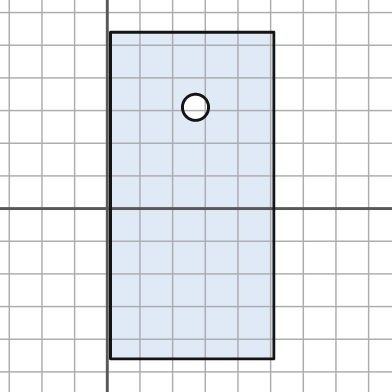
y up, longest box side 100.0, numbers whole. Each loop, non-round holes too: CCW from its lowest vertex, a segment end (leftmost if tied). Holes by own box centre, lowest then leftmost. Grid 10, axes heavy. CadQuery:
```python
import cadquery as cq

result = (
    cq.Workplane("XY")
    .moveTo(1.0, -46.0)
    .lineTo(51.0, -46.0)
    .lineTo(51.0, 54.0)
    .lineTo(1.0, 54.0)
    .close()
    .moveTo(27.0, 31.0)
    .circle(4.0)
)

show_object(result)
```